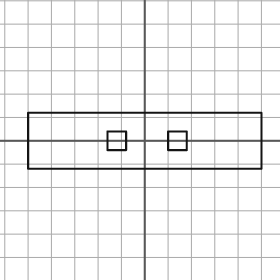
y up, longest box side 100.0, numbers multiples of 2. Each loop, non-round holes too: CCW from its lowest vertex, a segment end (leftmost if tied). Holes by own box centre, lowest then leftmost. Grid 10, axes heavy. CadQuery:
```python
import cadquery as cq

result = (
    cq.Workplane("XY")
    .moveTo(-50.0, -12.0)
    .lineTo(50.0, -12.0)
    .lineTo(50.0, 12.0)
    .lineTo(-50.0, 12.0)
    .close()
    .moveTo(-16.0, -4.0)
    .lineTo(-8.0, -4.0)
    .lineTo(-8.0, 4.0)
    .lineTo(-16.0, 4.0)
    .close()
    .moveTo(10.0, -4.0)
    .lineTo(18.0, -4.0)
    .lineTo(18.0, 4.0)
    .lineTo(10.0, 4.0)
    .close()
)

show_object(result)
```